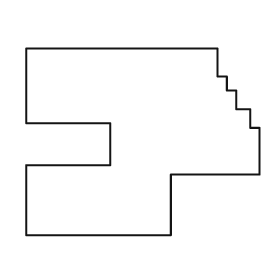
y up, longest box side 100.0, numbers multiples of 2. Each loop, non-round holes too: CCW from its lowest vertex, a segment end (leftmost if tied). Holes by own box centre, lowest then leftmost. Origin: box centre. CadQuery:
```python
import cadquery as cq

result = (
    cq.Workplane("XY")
    .moveTo(-50.0, -40.0)
    .lineTo(12.0, -40.0)
    .lineTo(12.0, -14.0)
    .lineTo(50.0, -14.0)
    .lineTo(50.0, 6.0)
    .lineTo(46.0, 6.0)
    .lineTo(46.0, 14.0)
    .lineTo(40.0, 14.0)
    .lineTo(40.0, 22.0)
    .lineTo(36.0, 22.0)
    .lineTo(36.0, 28.0)
    .lineTo(32.0, 28.0)
    .lineTo(32.0, 40.0)
    .lineTo(-50.0, 40.0)
    .lineTo(-50.0, 8.0)
    .lineTo(-14.0, 8.0)
    .lineTo(-14.0, -10.0)
    .lineTo(-50.0, -10.0)
    .close()
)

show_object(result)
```